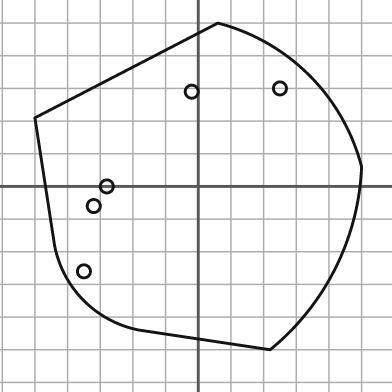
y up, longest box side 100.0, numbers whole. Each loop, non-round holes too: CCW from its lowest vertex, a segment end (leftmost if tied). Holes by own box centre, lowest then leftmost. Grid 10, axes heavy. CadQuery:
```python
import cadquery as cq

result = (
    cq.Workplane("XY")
    .moveTo(22.0, -50.0)
    .threePointArc((42.0, -25.0), (50.0, 6.0))
    .threePointArc((34.0, 34.0), (6.0, 50.0))
    .lineTo(-50.0, 21.0)
    .lineTo(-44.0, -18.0)
    .threePointArc((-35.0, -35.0), (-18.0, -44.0))
    .close()
    .moveTo(-35.0, -26.0)
    .circle(2.0)
    .moveTo(-32.0, -6.0)
    .circle(2.0)
    .moveTo(-28.0, 0.0)
    .circle(2.0)
    .moveTo(-2.0, 29.0)
    .circle(2.0)
    .moveTo(25.0, 30.0)
    .circle(2.0)
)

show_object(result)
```